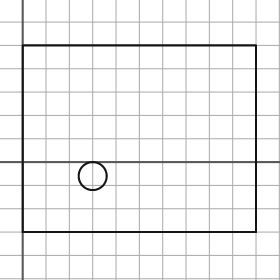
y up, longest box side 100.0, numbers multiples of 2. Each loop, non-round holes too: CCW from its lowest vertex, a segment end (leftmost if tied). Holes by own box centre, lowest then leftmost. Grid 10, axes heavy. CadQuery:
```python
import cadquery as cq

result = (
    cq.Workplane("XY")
    .moveTo(0.0, -30.0)
    .lineTo(100.0, -30.0)
    .lineTo(100.0, 50.0)
    .lineTo(0.0, 50.0)
    .close()
    .moveTo(30.0, -6.0)
    .circle(6.0)
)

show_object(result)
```